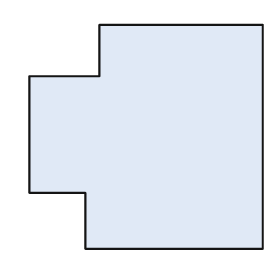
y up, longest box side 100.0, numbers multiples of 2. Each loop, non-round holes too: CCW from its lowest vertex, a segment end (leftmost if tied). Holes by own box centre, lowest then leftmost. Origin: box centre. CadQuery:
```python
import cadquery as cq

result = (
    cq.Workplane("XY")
    .moveTo(-26.0, -48.0)
    .lineTo(50.0, -48.0)
    .lineTo(50.0, 48.0)
    .lineTo(-20.0, 48.0)
    .lineTo(-20.0, 26.0)
    .lineTo(-50.0, 26.0)
    .lineTo(-50.0, -24.0)
    .lineTo(-26.0, -24.0)
    .close()
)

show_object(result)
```